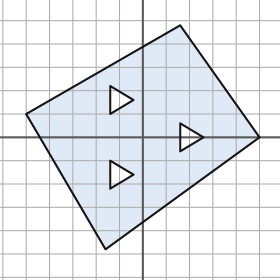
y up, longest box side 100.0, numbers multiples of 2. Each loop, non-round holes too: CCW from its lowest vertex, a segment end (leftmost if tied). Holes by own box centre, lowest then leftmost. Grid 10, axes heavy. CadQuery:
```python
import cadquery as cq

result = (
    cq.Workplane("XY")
    .moveTo(-16.0, -48.0)
    .lineTo(50.0, 0.0)
    .lineTo(16.0, 48.0)
    .lineTo(-50.0, 10.0)
    .close()
    .moveTo(-14.0, -22.0)
    .lineTo(-4.0, -16.0)
    .lineTo(-14.0, -10.0)
    .close()
    .moveTo(16.0, -6.0)
    .lineTo(26.0, 0.0)
    .lineTo(16.0, 6.0)
    .close()
    .moveTo(-14.0, 10.0)
    .lineTo(-4.0, 16.0)
    .lineTo(-14.0, 22.0)
    .close()
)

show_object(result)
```